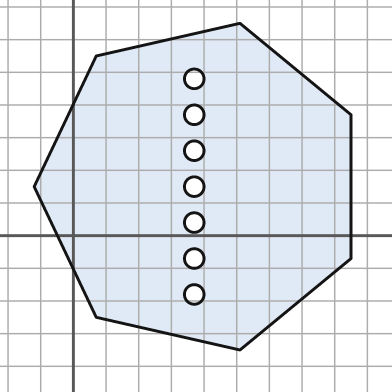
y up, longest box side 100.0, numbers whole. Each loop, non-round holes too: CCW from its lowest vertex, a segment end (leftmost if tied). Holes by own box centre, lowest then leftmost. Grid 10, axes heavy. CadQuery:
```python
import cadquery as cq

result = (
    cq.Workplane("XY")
    .moveTo(51.0, -35.0)
    .lineTo(85.0, -7.0)
    .lineTo(85.0, 37.0)
    .lineTo(51.0, 65.0)
    .lineTo(7.0, 55.0)
    .lineTo(-12.0, 15.0)
    .lineTo(7.0, -25.0)
    .close()
    .moveTo(37.0, -18.0)
    .circle(3.0)
    .moveTo(37.0, -7.0)
    .circle(3.0)
    .moveTo(37.0, 4.0)
    .circle(3.0)
    .moveTo(37.0, 15.0)
    .circle(3.0)
    .moveTo(37.0, 26.0)
    .circle(3.0)
    .moveTo(37.0, 37.0)
    .circle(3.0)
    .moveTo(37.0, 48.0)
    .circle(3.0)
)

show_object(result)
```